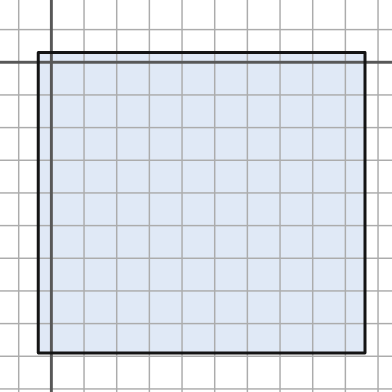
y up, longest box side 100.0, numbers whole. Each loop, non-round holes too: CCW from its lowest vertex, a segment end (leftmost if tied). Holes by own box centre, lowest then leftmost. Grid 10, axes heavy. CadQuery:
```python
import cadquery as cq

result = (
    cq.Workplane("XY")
    .moveTo(-4.0, -89.0)
    .lineTo(96.0, -89.0)
    .lineTo(96.0, 3.0)
    .lineTo(-4.0, 3.0)
    .close()
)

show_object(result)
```